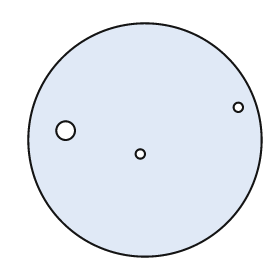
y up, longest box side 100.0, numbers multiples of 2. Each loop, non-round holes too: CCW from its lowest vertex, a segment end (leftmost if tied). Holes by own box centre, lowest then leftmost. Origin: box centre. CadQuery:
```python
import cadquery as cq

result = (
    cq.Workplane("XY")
    .moveTo(0.0, 0.0)
    .circle(50.0)
    .moveTo(-2.0, -6.0)
    .circle(2.0)
    .moveTo(-34.0, 4.0)
    .circle(4.0)
    .moveTo(40.0, 14.0)
    .circle(2.0)
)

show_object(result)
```